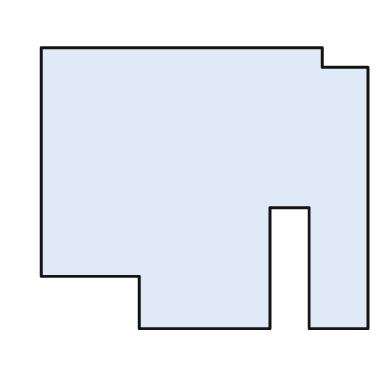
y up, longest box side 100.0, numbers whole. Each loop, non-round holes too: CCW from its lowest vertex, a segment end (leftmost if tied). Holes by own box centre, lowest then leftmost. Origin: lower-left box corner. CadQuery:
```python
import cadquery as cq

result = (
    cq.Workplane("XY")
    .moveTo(30.0, 0.0)
    .lineTo(70.0, 0.0)
    .lineTo(70.0, 37.0)
    .lineTo(82.0, 37.0)
    .lineTo(82.0, 0.0)
    .lineTo(100.0, 0.0)
    .lineTo(100.0, 80.0)
    .lineTo(86.0, 80.0)
    .lineTo(86.0, 86.0)
    .lineTo(0.0, 86.0)
    .lineTo(0.0, 16.0)
    .lineTo(30.0, 16.0)
    .close()
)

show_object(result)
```